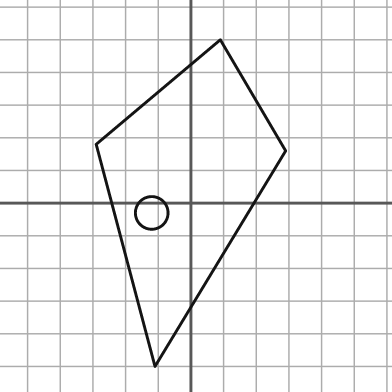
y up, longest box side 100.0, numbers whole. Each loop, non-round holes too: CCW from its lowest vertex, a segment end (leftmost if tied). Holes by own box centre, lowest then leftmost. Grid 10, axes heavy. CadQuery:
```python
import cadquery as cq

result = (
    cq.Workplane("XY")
    .moveTo(-11.0, -50.0)
    .lineTo(29.0, 16.0)
    .lineTo(9.0, 50.0)
    .lineTo(-29.0, 18.0)
    .close()
    .moveTo(-12.0, -3.0)
    .circle(5.0)
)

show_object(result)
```